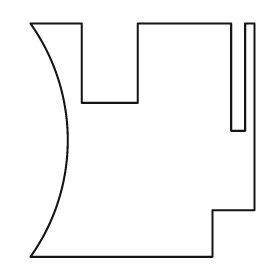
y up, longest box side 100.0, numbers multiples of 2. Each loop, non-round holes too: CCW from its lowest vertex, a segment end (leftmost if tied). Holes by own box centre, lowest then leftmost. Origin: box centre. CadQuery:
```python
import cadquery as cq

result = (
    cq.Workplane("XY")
    .moveTo(-48.0, -50.0)
    .lineTo(30.0, -50.0)
    .lineTo(30.0, -30.0)
    .lineTo(48.0, -30.0)
    .lineTo(48.0, 50.0)
    .lineTo(44.0, 50.0)
    .lineTo(44.0, 4.0)
    .lineTo(38.0, 4.0)
    .lineTo(38.0, 50.0)
    .lineTo(-2.0, 50.0)
    .lineTo(-2.0, 16.0)
    .lineTo(-26.0, 16.0)
    .lineTo(-26.0, 50.0)
    .lineTo(-48.0, 50.0)
    .threePointArc((-32.0, 0.0), (-48.0, -50.0))
    .close()
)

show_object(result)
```